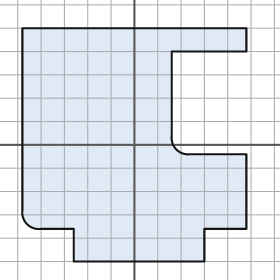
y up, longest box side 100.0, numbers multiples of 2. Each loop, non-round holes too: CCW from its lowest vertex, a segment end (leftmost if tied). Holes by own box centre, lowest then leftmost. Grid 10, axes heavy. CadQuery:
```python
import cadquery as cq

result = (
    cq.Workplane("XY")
    .moveTo(-26.0, -50.0)
    .lineTo(30.0, -50.0)
    .lineTo(30.0, -36.0)
    .lineTo(48.0, -36.0)
    .lineTo(48.0, -4.0)
    .lineTo(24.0, -4.0)
    .threePointArc((18.0, -2.0), (16.0, 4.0))
    .lineTo(16.0, 40.0)
    .lineTo(48.0, 40.0)
    .lineTo(48.0, 50.0)
    .lineTo(-48.0, 50.0)
    .lineTo(-48.0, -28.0)
    .threePointArc((-46.0, -34.0), (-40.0, -36.0))
    .lineTo(-26.0, -36.0)
    .close()
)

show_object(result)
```